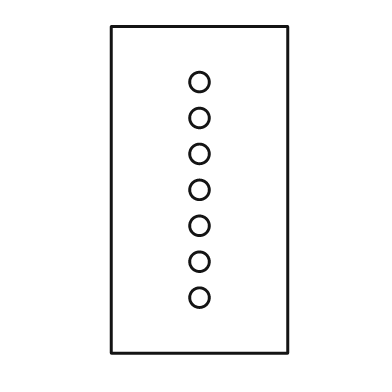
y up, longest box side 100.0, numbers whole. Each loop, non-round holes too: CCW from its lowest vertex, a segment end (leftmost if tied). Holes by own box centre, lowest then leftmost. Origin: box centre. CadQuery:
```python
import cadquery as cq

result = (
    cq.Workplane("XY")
    .moveTo(-27.0, -50.0)
    .lineTo(27.0, -50.0)
    .lineTo(27.0, 50.0)
    .lineTo(-27.0, 50.0)
    .close()
    .moveTo(0.0, -33.0)
    .circle(3.0)
    .moveTo(0.0, -22.0)
    .circle(3.0)
    .moveTo(0.0, -11.0)
    .circle(3.0)
    .moveTo(0.0, 0.0)
    .circle(3.0)
    .moveTo(0.0, 11.0)
    .circle(3.0)
    .moveTo(0.0, 22.0)
    .circle(3.0)
    .moveTo(0.0, 33.0)
    .circle(3.0)
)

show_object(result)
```